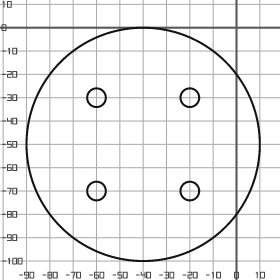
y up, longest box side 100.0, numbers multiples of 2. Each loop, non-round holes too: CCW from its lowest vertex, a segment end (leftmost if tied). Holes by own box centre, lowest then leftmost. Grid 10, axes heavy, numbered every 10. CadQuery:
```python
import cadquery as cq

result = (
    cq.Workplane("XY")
    .moveTo(-40.0, -50.0)
    .circle(50.0)
    .moveTo(-60.0, -70.0)
    .circle(4.0)
    .moveTo(-20.0, -70.0)
    .circle(4.0)
    .moveTo(-60.0, -30.0)
    .circle(4.0)
    .moveTo(-20.0, -30.0)
    .circle(4.0)
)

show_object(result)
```